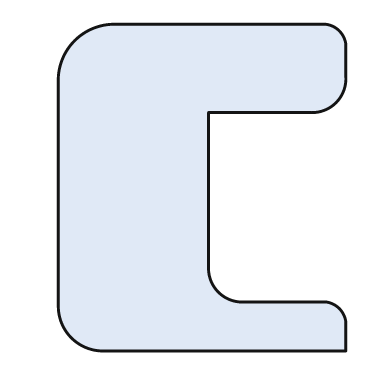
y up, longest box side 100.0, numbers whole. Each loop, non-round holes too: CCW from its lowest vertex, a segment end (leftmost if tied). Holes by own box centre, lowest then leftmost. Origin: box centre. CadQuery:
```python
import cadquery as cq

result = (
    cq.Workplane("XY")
    .moveTo(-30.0, -50.0)
    .lineTo(44.0, -50.0)
    .lineTo(44.0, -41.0)
    .threePointArc((42.0, -37.0), (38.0, -35.0))
    .lineTo(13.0, -35.0)
    .threePointArc((5.0, -32.0), (2.0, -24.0))
    .lineTo(2.0, 23.0)
    .lineTo(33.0, 23.0)
    .threePointArc((41.0, 26.0), (44.0, 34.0))
    .lineTo(44.0, 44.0)
    .threePointArc((42.0, 48.0), (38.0, 50.0))
    .lineTo(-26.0, 50.0)
    .threePointArc((-39.0, 45.0), (-44.0, 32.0))
    .lineTo(-44.0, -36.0)
    .threePointArc((-40.0, -46.0), (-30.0, -50.0))
    .close()
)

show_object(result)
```